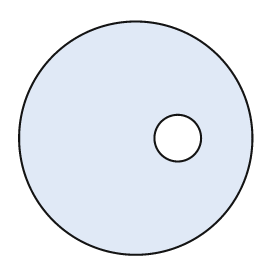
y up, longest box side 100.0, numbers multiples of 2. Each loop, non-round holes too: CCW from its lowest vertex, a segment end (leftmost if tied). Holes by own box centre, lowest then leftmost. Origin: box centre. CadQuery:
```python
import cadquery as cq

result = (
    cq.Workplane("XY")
    .moveTo(0.0, 0.0)
    .circle(50.0)
    .moveTo(18.0, 0.0)
    .circle(10.0)
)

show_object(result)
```